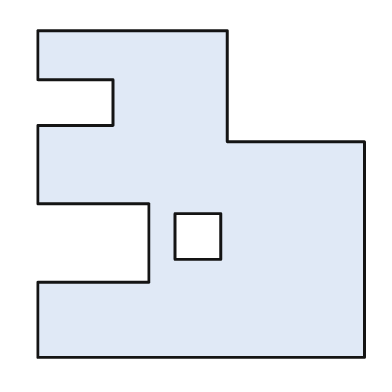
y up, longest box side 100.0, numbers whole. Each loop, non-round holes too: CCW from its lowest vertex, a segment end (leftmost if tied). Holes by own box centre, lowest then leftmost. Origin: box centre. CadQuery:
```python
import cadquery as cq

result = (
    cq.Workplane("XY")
    .moveTo(-50.0, -50.0)
    .lineTo(50.0, -50.0)
    .lineTo(50.0, 16.0)
    .lineTo(8.0, 16.0)
    .lineTo(8.0, 50.0)
    .lineTo(-50.0, 50.0)
    .lineTo(-50.0, 35.0)
    .lineTo(-27.0, 35.0)
    .lineTo(-27.0, 21.0)
    .lineTo(-50.0, 21.0)
    .lineTo(-50.0, -3.0)
    .lineTo(-16.0, -3.0)
    .lineTo(-16.0, -27.0)
    .lineTo(-50.0, -27.0)
    .close()
    .moveTo(-8.0, -20.0)
    .lineTo(6.0, -20.0)
    .lineTo(6.0, -6.0)
    .lineTo(-8.0, -6.0)
    .close()
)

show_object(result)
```